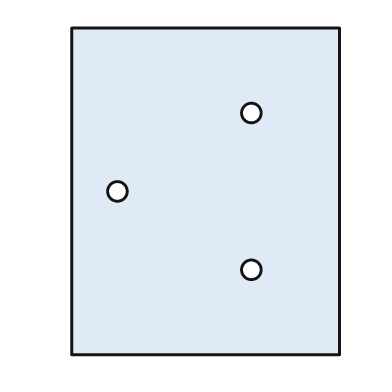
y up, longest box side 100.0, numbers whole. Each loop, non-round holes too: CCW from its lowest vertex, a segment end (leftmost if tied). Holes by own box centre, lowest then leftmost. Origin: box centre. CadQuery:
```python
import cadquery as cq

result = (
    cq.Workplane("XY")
    .moveTo(-41.0, -50.0)
    .lineTo(41.0, -50.0)
    .lineTo(41.0, 50.0)
    .lineTo(-41.0, 50.0)
    .close()
    .moveTo(14.0, -24.0)
    .circle(3.0)
    .moveTo(-27.0, 0.0)
    .circle(3.0)
    .moveTo(14.0, 24.0)
    .circle(3.0)
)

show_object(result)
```